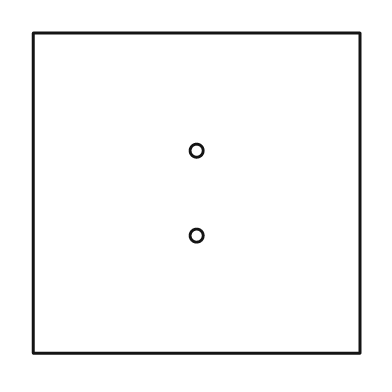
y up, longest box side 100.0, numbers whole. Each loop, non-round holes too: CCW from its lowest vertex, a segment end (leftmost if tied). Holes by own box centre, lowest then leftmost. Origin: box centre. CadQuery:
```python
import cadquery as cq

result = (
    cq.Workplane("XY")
    .moveTo(-50.0, -49.0)
    .lineTo(50.0, -49.0)
    .lineTo(50.0, 49.0)
    .lineTo(-50.0, 49.0)
    .close()
    .moveTo(0.0, -13.0)
    .circle(2.0)
    .moveTo(0.0, 13.0)
    .circle(2.0)
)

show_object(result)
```